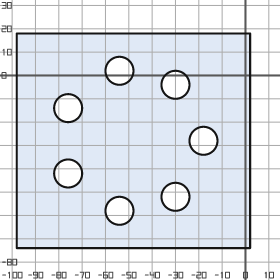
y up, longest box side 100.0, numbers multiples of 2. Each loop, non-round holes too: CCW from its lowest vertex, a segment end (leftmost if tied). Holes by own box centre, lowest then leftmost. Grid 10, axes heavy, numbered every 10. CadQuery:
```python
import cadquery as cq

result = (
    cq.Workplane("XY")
    .moveTo(-98.0, -74.0)
    .lineTo(2.0, -74.0)
    .lineTo(2.0, 18.0)
    .lineTo(-98.0, 18.0)
    .close()
    .moveTo(-54.0, -58.0)
    .circle(6.0)
    .moveTo(-30.0, -52.0)
    .circle(6.0)
    .moveTo(-76.0, -42.0)
    .circle(6.0)
    .moveTo(-18.0, -28.0)
    .circle(6.0)
    .moveTo(-76.0, -14.0)
    .circle(6.0)
    .moveTo(-30.0, -4.0)
    .circle(6.0)
    .moveTo(-54.0, 2.0)
    .circle(6.0)
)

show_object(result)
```